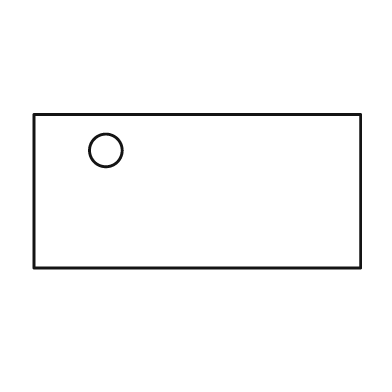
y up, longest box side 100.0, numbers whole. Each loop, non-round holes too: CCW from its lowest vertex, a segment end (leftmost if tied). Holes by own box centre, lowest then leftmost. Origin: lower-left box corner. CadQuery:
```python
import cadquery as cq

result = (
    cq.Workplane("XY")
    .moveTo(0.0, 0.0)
    .lineTo(100.0, 0.0)
    .lineTo(100.0, 47.0)
    .lineTo(0.0, 47.0)
    .close()
    .moveTo(22.0, 36.0)
    .circle(5.0)
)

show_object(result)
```